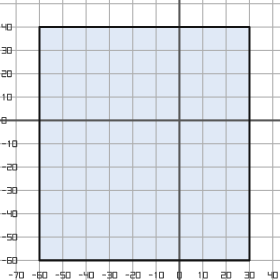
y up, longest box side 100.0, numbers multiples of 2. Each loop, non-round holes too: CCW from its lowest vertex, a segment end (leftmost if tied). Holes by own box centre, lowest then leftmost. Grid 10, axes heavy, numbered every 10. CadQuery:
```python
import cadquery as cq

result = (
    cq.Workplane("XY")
    .moveTo(-60.0, -60.0)
    .lineTo(30.0, -60.0)
    .lineTo(30.0, 40.0)
    .lineTo(-60.0, 40.0)
    .close()
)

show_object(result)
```